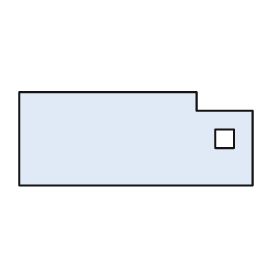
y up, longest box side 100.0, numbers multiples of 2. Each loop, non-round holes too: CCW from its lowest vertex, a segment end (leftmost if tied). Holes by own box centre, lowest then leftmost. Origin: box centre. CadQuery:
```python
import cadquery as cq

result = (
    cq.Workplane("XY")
    .moveTo(-50.0, -20.0)
    .lineTo(50.0, -20.0)
    .lineTo(50.0, 12.0)
    .lineTo(26.0, 12.0)
    .lineTo(26.0, 20.0)
    .lineTo(-50.0, 20.0)
    .close()
    .moveTo(34.0, -4.0)
    .lineTo(42.0, -4.0)
    .lineTo(42.0, 4.0)
    .lineTo(34.0, 4.0)
    .close()
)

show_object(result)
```